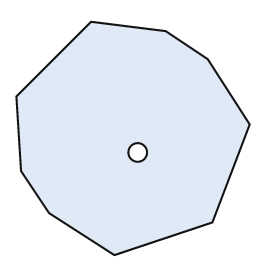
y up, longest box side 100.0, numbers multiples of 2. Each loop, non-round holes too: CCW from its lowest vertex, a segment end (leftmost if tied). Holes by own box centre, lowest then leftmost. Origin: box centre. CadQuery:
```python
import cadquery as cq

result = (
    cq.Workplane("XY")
    .moveTo(-8.0, -50.0)
    .lineTo(34.0, -36.0)
    .lineTo(50.0, 6.0)
    .lineTo(32.0, 34.0)
    .lineTo(14.0, 46.0)
    .lineTo(-18.0, 50.0)
    .lineTo(-50.0, 18.0)
    .lineTo(-48.0, -14.0)
    .lineTo(-36.0, -32.0)
    .close()
    .moveTo(2.0, -6.0)
    .circle(4.0)
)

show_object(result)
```